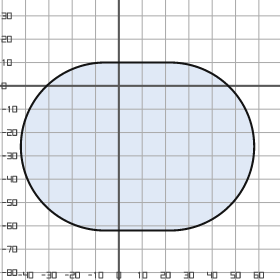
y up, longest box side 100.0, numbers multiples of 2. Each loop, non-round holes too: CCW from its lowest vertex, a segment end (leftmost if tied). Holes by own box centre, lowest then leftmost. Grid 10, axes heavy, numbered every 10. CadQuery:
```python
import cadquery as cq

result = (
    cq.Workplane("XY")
    .moveTo(-6.0, -62.0)
    .lineTo(22.0, -62.0)
    .threePointArc((58.0, -26.0), (22.0, 10.0))
    .lineTo(-6.0, 10.0)
    .threePointArc((-42.0, -26.0), (-6.0, -62.0))
    .close()
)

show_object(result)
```